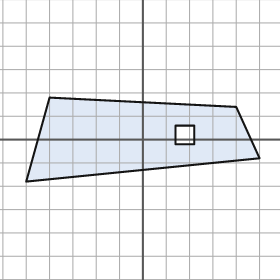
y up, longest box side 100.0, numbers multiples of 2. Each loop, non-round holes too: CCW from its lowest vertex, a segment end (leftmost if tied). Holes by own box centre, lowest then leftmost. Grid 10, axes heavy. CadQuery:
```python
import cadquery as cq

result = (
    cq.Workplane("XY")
    .moveTo(-50.0, -18.0)
    .lineTo(50.0, -8.0)
    .lineTo(40.0, 14.0)
    .lineTo(-40.0, 18.0)
    .close()
    .moveTo(14.0, -2.0)
    .lineTo(22.0, -2.0)
    .lineTo(22.0, 6.0)
    .lineTo(14.0, 6.0)
    .close()
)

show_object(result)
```